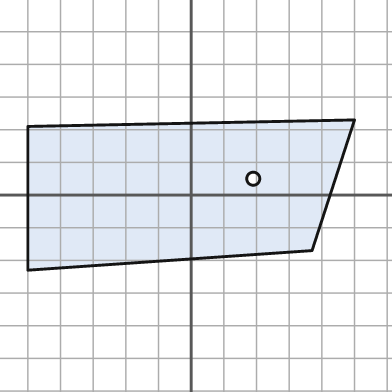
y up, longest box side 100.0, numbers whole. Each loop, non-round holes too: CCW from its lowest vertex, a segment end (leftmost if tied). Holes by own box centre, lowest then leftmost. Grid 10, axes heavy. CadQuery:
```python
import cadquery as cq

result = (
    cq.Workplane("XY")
    .moveTo(-50.0, -23.0)
    .lineTo(37.0, -17.0)
    .lineTo(50.0, 23.0)
    .lineTo(-50.0, 21.0)
    .close()
    .moveTo(19.0, 5.0)
    .circle(2.0)
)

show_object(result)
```